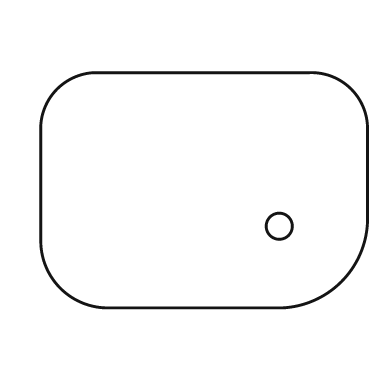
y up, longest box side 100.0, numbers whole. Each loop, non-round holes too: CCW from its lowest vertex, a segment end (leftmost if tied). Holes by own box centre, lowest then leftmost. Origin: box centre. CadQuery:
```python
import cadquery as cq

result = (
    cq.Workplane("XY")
    .moveTo(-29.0, -36.0)
    .lineTo(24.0, -36.0)
    .threePointArc((42.0, -28.0), (50.0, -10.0))
    .lineTo(50.0, 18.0)
    .threePointArc((45.0, 31.0), (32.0, 36.0))
    .lineTo(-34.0, 36.0)
    .threePointArc((-45.0, 31.0), (-50.0, 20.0))
    .lineTo(-50.0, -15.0)
    .threePointArc((-44.0, -30.0), (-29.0, -36.0))
    .close()
    .moveTo(23.0, -11.0)
    .circle(4.0)
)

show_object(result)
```